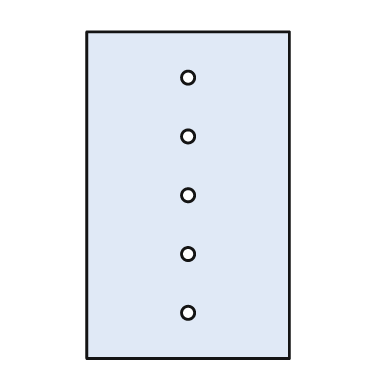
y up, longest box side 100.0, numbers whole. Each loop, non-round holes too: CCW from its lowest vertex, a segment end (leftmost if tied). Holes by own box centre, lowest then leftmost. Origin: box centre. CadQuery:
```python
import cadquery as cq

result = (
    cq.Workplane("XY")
    .moveTo(-31.0, -50.0)
    .lineTo(31.0, -50.0)
    .lineTo(31.0, 50.0)
    .lineTo(-31.0, 50.0)
    .close()
    .moveTo(0.0, -36.0)
    .circle(2.0)
    .moveTo(0.0, -18.0)
    .circle(2.0)
    .moveTo(0.0, 0.0)
    .circle(2.0)
    .moveTo(0.0, 18.0)
    .circle(2.0)
    .moveTo(0.0, 36.0)
    .circle(2.0)
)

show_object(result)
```